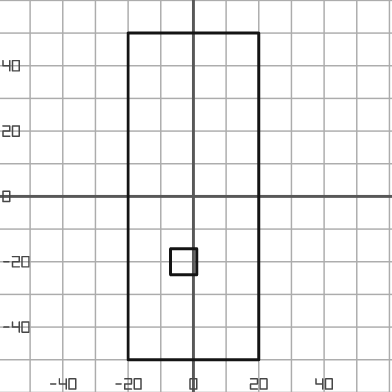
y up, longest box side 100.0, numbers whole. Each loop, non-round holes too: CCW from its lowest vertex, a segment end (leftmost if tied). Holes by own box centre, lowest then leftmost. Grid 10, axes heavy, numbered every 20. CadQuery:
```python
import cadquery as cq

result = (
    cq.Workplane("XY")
    .moveTo(-20.0, -50.0)
    .lineTo(20.0, -50.0)
    .lineTo(20.0, 50.0)
    .lineTo(-20.0, 50.0)
    .close()
    .moveTo(-7.0, -24.0)
    .lineTo(1.0, -24.0)
    .lineTo(1.0, -16.0)
    .lineTo(-7.0, -16.0)
    .close()
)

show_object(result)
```